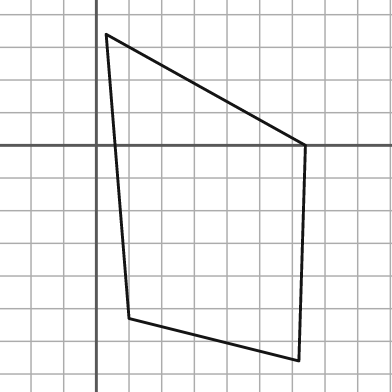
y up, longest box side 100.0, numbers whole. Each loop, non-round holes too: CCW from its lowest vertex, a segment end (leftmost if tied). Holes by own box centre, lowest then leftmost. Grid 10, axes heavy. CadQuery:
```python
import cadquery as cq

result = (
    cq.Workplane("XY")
    .moveTo(62.0, -66.0)
    .lineTo(64.0, 0.0)
    .lineTo(3.0, 34.0)
    .lineTo(10.0, -53.0)
    .close()
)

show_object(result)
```